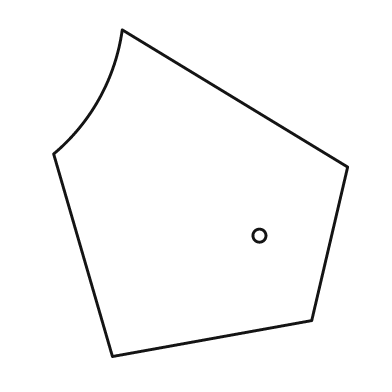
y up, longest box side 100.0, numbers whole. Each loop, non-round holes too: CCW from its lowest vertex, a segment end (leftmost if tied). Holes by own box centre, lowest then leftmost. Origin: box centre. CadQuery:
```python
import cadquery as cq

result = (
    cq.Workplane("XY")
    .moveTo(-27.0, -50.0)
    .lineTo(34.0, -39.0)
    .lineTo(45.0, 8.0)
    .lineTo(-24.0, 50.0)
    .threePointArc((-31.0, 29.0), (-45.0, 12.0))
    .close()
    .moveTo(18.0, -13.0)
    .circle(2.0)
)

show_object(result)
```